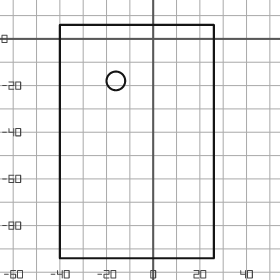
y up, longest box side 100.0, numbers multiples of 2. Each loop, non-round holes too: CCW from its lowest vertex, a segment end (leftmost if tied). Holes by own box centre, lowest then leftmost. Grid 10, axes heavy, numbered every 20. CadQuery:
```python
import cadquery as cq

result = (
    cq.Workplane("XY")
    .moveTo(-40.0, -94.0)
    .lineTo(26.0, -94.0)
    .lineTo(26.0, 6.0)
    .lineTo(-40.0, 6.0)
    .close()
    .moveTo(-16.0, -18.0)
    .circle(4.0)
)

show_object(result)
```